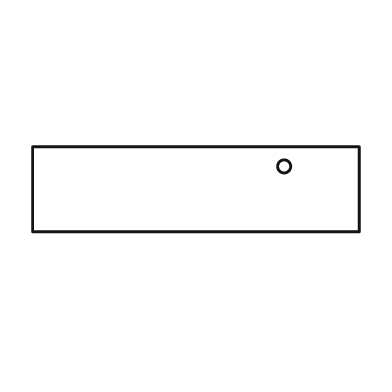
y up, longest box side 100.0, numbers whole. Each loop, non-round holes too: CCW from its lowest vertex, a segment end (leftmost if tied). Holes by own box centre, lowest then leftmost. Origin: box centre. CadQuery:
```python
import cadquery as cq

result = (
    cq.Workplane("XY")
    .moveTo(-50.0, -13.0)
    .lineTo(50.0, -13.0)
    .lineTo(50.0, 13.0)
    .lineTo(-50.0, 13.0)
    .close()
    .moveTo(27.0, 7.0)
    .circle(2.0)
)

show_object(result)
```